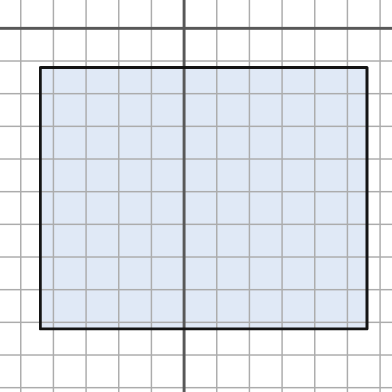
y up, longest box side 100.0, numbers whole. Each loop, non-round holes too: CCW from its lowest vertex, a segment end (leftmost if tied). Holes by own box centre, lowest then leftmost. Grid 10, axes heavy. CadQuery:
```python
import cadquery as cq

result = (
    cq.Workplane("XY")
    .moveTo(-44.0, -92.0)
    .lineTo(56.0, -92.0)
    .lineTo(56.0, -12.0)
    .lineTo(-44.0, -12.0)
    .close()
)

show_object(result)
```